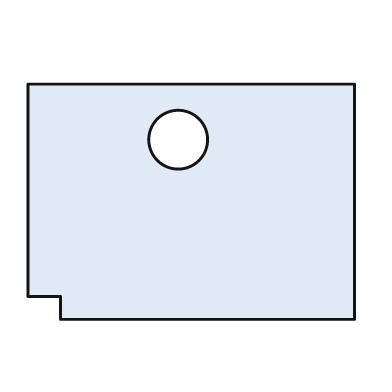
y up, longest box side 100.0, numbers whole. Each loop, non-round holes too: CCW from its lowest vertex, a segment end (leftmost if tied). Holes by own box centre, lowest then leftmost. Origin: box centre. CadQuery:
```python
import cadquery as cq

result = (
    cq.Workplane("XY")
    .moveTo(-40.0, -36.0)
    .lineTo(50.0, -36.0)
    .lineTo(50.0, 36.0)
    .lineTo(-50.0, 36.0)
    .lineTo(-50.0, -29.0)
    .lineTo(-40.0, -29.0)
    .close()
    .moveTo(-4.0, 19.0)
    .circle(9.0)
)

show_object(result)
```